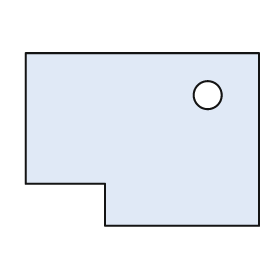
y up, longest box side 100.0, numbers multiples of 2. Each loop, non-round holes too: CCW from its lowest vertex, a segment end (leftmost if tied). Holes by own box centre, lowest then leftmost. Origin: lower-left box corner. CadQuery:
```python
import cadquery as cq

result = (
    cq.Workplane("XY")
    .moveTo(34.0, 0.0)
    .lineTo(100.0, 0.0)
    .lineTo(100.0, 74.0)
    .lineTo(0.0, 74.0)
    .lineTo(0.0, 18.0)
    .lineTo(34.0, 18.0)
    .close()
    .moveTo(78.0, 56.0)
    .circle(6.0)
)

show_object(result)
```